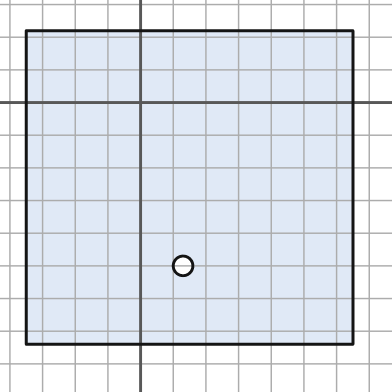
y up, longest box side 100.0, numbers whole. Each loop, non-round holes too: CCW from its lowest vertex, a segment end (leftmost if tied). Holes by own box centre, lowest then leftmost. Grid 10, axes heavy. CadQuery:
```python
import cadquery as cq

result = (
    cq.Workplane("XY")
    .moveTo(-35.0, -74.0)
    .lineTo(65.0, -74.0)
    .lineTo(65.0, 22.0)
    .lineTo(-35.0, 22.0)
    .close()
    .moveTo(13.0, -50.0)
    .circle(3.0)
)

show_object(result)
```